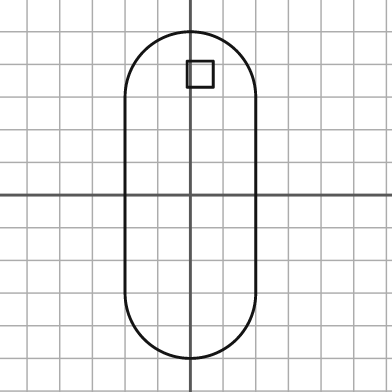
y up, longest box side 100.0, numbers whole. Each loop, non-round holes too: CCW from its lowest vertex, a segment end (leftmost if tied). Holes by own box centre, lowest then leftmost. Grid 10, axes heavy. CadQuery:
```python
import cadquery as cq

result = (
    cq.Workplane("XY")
    .moveTo(-20.0, -30.0)
    .threePointArc((0.0, -50.0), (20.0, -30.0))
    .lineTo(20.0, 30.0)
    .threePointArc((0.0, 50.0), (-20.0, 30.0))
    .close()
    .moveTo(-1.0, 33.0)
    .lineTo(7.0, 33.0)
    .lineTo(7.0, 41.0)
    .lineTo(-1.0, 41.0)
    .close()
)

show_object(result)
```